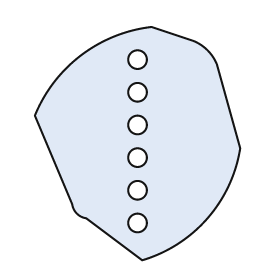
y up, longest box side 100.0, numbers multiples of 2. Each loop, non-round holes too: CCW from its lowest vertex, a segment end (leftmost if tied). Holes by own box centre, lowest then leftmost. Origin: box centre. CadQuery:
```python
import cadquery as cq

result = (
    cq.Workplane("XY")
    .moveTo(2.0, -50.0)
    .threePointArc((30.0, -32.0), (44.0, -2.0))
    .lineTo(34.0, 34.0)
    .threePointArc((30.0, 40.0), (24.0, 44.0))
    .lineTo(6.0, 50.0)
    .threePointArc((-24.0, 38.0), (-44.0, 12.0))
    .lineTo(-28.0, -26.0)
    .threePointArc((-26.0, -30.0), (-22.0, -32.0))
    .close()
    .moveTo(0.0, -34.0)
    .circle(4.0)
    .moveTo(0.0, -20.0)
    .circle(4.0)
    .moveTo(0.0, -6.0)
    .circle(4.0)
    .moveTo(0.0, 8.0)
    .circle(4.0)
    .moveTo(0.0, 22.0)
    .circle(4.0)
    .moveTo(0.0, 36.0)
    .circle(4.0)
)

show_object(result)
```